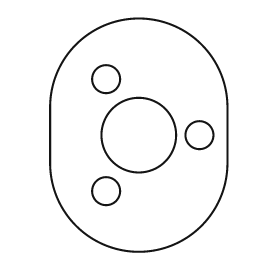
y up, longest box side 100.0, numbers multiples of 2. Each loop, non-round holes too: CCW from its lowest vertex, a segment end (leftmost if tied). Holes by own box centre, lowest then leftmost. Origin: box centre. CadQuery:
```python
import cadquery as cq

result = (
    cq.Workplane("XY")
    .moveTo(-38.0, -12.0)
    .threePointArc((0.0, -50.0), (38.0, -12.0))
    .lineTo(38.0, 12.0)
    .threePointArc((0.0, 50.0), (-38.0, 12.0))
    .close()
    .moveTo(-14.0, -24.0)
    .circle(6.0)
    .moveTo(0.0, 0.0)
    .circle(16.0)
    .moveTo(26.0, 0.0)
    .circle(6.0)
    .moveTo(-14.0, 24.0)
    .circle(6.0)
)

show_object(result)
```